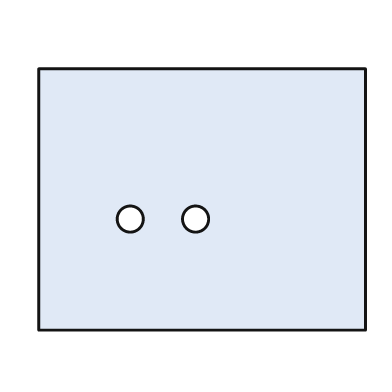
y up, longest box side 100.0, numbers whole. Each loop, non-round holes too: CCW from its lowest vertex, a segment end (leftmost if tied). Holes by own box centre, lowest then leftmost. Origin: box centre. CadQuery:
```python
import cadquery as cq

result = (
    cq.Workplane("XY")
    .moveTo(-50.0, -40.0)
    .lineTo(50.0, -40.0)
    .lineTo(50.0, 40.0)
    .lineTo(-50.0, 40.0)
    .close()
    .moveTo(-22.0, -6.0)
    .circle(4.0)
    .moveTo(-2.0, -6.0)
    .circle(4.0)
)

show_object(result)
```